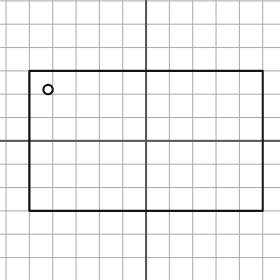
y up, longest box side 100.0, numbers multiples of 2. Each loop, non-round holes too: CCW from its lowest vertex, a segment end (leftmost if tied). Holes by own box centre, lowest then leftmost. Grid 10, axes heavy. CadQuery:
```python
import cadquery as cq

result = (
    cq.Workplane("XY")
    .moveTo(-50.0, -30.0)
    .lineTo(50.0, -30.0)
    .lineTo(50.0, 30.0)
    .lineTo(-50.0, 30.0)
    .close()
    .moveTo(-42.0, 22.0)
    .circle(2.0)
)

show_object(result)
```